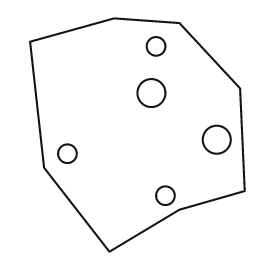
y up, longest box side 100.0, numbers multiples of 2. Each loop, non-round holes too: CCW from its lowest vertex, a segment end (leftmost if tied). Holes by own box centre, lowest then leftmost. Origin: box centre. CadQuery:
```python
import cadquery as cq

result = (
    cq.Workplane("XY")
    .moveTo(-12.0, -50.0)
    .lineTo(18.0, -32.0)
    .lineTo(46.0, -24.0)
    .lineTo(44.0, 20.0)
    .lineTo(18.0, 48.0)
    .lineTo(-10.0, 50.0)
    .lineTo(-46.0, 40.0)
    .lineTo(-40.0, -14.0)
    .close()
    .moveTo(12.0, -26.0)
    .circle(4.0)
    .moveTo(-30.0, -8.0)
    .circle(4.0)
    .moveTo(34.0, -2.0)
    .circle(6.0)
    .moveTo(6.0, 18.0)
    .circle(6.0)
    .moveTo(8.0, 38.0)
    .circle(4.0)
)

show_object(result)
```